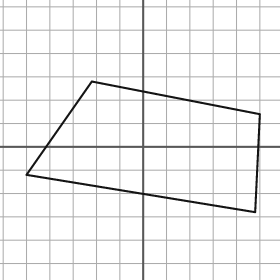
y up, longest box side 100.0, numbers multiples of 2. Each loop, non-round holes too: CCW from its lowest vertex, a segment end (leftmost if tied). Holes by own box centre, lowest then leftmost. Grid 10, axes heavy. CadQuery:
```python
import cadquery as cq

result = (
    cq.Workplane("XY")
    .moveTo(48.0, -28.0)
    .lineTo(50.0, 14.0)
    .lineTo(-22.0, 28.0)
    .lineTo(-50.0, -12.0)
    .close()
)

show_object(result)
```